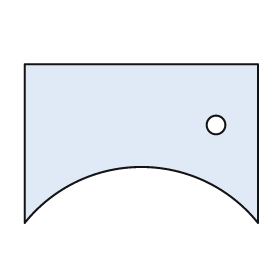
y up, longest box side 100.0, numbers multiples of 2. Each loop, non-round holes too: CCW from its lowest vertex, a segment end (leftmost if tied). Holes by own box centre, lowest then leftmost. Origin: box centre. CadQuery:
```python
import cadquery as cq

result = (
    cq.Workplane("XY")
    .moveTo(-50.0, -34.0)
    .threePointArc((0.0, -10.0), (50.0, -34.0))
    .lineTo(50.0, 34.0)
    .lineTo(-50.0, 34.0)
    .close()
    .moveTo(32.0, 8.0)
    .circle(4.0)
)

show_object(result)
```